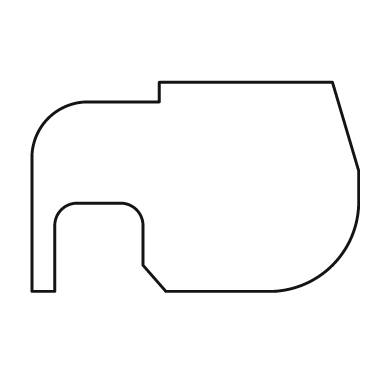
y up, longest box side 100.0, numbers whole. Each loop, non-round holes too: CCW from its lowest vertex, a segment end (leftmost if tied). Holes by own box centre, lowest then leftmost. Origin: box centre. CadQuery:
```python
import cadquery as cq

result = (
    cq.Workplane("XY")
    .moveTo(-50.0, -32.0)
    .lineTo(-43.0, -32.0)
    .lineTo(-43.0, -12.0)
    .threePointArc((-41.0, -7.0), (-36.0, -5.0))
    .lineTo(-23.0, -5.0)
    .threePointArc((-18.0, -7.0), (-16.0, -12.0))
    .lineTo(-16.0, -24.0)
    .lineTo(-9.0, -32.0)
    .lineTo(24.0, -32.0)
    .threePointArc((42.0, -24.0), (50.0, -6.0))
    .lineTo(50.0, 5.0)
    .lineTo(42.0, 32.0)
    .lineTo(-11.0, 32.0)
    .lineTo(-11.0, 26.0)
    .lineTo(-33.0, 26.0)
    .threePointArc((-45.0, 21.0), (-50.0, 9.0))
    .close()
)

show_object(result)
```